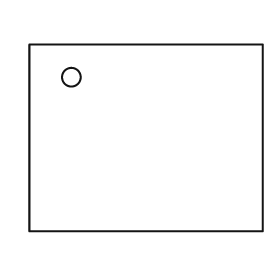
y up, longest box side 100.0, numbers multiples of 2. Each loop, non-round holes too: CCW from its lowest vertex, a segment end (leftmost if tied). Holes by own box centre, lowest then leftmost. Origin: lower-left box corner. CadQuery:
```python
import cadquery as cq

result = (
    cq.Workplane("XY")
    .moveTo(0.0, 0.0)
    .lineTo(100.0, 0.0)
    .lineTo(100.0, 80.0)
    .lineTo(0.0, 80.0)
    .close()
    .moveTo(18.0, 66.0)
    .circle(4.0)
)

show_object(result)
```